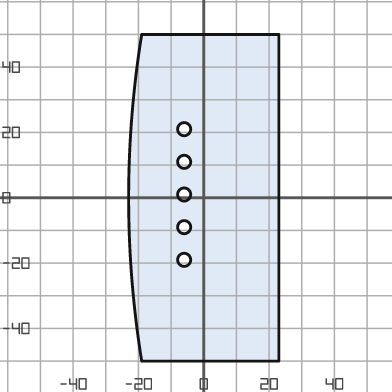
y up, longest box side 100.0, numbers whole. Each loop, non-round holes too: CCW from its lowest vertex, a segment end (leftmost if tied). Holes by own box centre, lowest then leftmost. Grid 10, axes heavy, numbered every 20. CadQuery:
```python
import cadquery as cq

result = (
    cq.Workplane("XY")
    .moveTo(-19.0, -50.0)
    .lineTo(23.0, -50.0)
    .lineTo(23.0, 50.0)
    .lineTo(-19.0, 50.0)
    .threePointArc((-23.0, 0.0), (-19.0, -50.0))
    .close()
    .moveTo(-6.0, -19.0)
    .circle(2.0)
    .moveTo(-6.0, -9.0)
    .circle(2.0)
    .moveTo(-6.0, 1.0)
    .circle(2.0)
    .moveTo(-6.0, 11.0)
    .circle(2.0)
    .moveTo(-6.0, 21.0)
    .circle(2.0)
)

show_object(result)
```